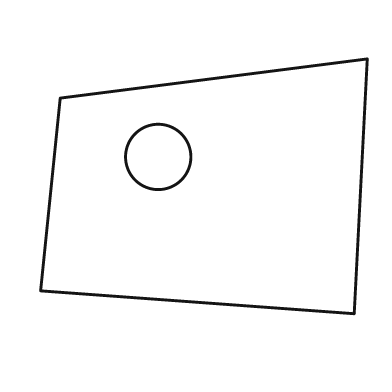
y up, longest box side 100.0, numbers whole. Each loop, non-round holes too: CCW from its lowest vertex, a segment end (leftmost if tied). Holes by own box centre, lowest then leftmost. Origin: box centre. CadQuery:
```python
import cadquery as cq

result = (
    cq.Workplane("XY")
    .moveTo(46.0, -39.0)
    .lineTo(50.0, 39.0)
    .lineTo(-44.0, 27.0)
    .lineTo(-50.0, -32.0)
    .close()
    .moveTo(-14.0, 9.0)
    .circle(10.0)
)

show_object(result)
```